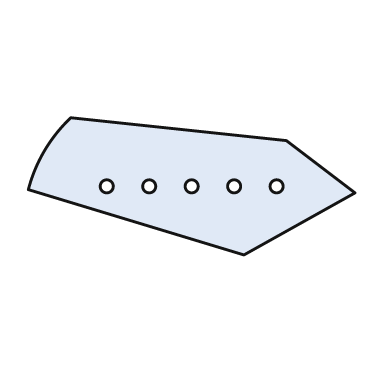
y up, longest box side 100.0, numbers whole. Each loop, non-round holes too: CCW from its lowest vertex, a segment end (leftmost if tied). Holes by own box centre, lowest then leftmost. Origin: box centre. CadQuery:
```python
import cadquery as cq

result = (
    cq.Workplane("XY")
    .moveTo(16.0, -21.0)
    .lineTo(50.0, -2.0)
    .lineTo(29.0, 14.0)
    .lineTo(-37.0, 21.0)
    .threePointArc((-45.0, 11.0), (-50.0, -1.0))
    .close()
    .moveTo(-26.0, 0.0)
    .circle(2.0)
    .moveTo(-13.0, 0.0)
    .circle(2.0)
    .moveTo(0.0, 0.0)
    .circle(2.0)
    .moveTo(13.0, 0.0)
    .circle(2.0)
    .moveTo(26.0, 0.0)
    .circle(2.0)
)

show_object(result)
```